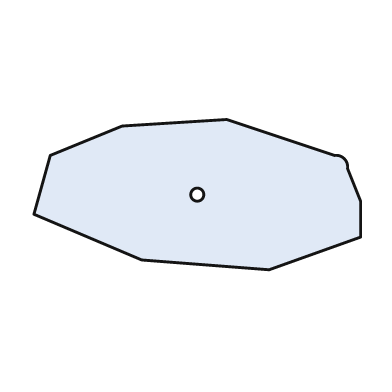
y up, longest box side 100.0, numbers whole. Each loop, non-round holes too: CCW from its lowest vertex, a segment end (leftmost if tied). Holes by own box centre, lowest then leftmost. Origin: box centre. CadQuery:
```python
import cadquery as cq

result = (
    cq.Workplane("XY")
    .moveTo(22.0, -23.0)
    .lineTo(50.0, -13.0)
    .lineTo(50.0, -2.0)
    .lineTo(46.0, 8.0)
    .threePointArc((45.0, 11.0), (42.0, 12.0))
    .lineTo(9.0, 23.0)
    .lineTo(-23.0, 21.0)
    .lineTo(-45.0, 12.0)
    .lineTo(-50.0, -6.0)
    .lineTo(-17.0, -20.0)
    .close()
    .moveTo(0.0, 0.0)
    .circle(2.0)
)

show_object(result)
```